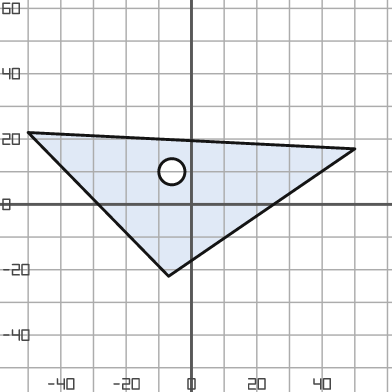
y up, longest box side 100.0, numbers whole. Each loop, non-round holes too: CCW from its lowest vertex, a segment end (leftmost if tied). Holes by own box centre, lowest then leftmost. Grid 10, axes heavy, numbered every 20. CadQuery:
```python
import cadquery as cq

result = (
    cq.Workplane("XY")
    .moveTo(-7.0, -22.0)
    .lineTo(50.0, 17.0)
    .lineTo(-50.0, 22.0)
    .close()
    .moveTo(-6.0, 10.0)
    .circle(4.0)
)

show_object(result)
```